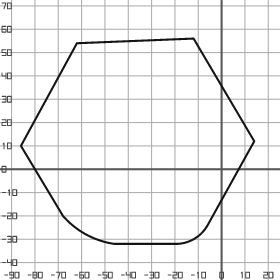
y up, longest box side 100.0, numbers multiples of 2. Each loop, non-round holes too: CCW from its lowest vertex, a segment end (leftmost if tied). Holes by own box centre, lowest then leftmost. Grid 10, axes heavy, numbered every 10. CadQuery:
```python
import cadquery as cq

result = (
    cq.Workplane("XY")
    .moveTo(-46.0, -32.0)
    .lineTo(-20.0, -32.0)
    .threePointArc((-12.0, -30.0), (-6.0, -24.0))
    .lineTo(14.0, 12.0)
    .lineTo(-12.0, 56.0)
    .lineTo(-62.0, 54.0)
    .lineTo(-86.0, 10.0)
    .lineTo(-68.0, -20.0)
    .threePointArc((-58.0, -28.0), (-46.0, -32.0))
    .close()
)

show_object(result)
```